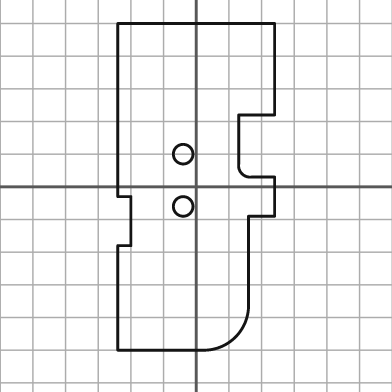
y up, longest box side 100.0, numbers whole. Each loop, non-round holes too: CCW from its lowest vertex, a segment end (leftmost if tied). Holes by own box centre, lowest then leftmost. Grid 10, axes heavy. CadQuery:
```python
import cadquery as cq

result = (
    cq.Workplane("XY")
    .moveTo(-24.0, -50.0)
    .lineTo(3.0, -50.0)
    .threePointArc((12.0, -46.0), (16.0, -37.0))
    .lineTo(16.0, -9.0)
    .lineTo(24.0, -9.0)
    .lineTo(24.0, 3.0)
    .lineTo(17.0, 3.0)
    .threePointArc((14.0, 4.0), (13.0, 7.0))
    .lineTo(13.0, 22.0)
    .lineTo(24.0, 22.0)
    .lineTo(24.0, 50.0)
    .lineTo(-24.0, 50.0)
    .lineTo(-24.0, -3.0)
    .lineTo(-20.0, -3.0)
    .lineTo(-20.0, -18.0)
    .lineTo(-24.0, -18.0)
    .close()
    .moveTo(-4.0, -6.0)
    .circle(3.0)
    .moveTo(-4.0, 10.0)
    .circle(3.0)
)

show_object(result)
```